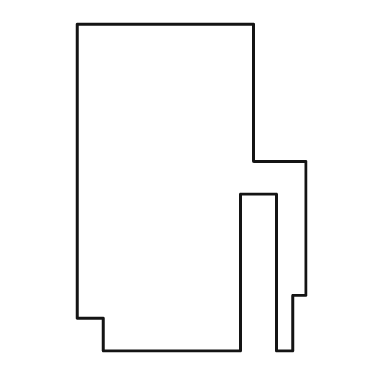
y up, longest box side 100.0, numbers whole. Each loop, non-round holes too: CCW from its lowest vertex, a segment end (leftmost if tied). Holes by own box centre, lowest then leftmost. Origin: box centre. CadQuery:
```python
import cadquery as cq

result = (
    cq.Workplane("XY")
    .moveTo(-27.0, -50.0)
    .lineTo(15.0, -50.0)
    .lineTo(15.0, -2.0)
    .lineTo(26.0, -2.0)
    .lineTo(26.0, -50.0)
    .lineTo(31.0, -50.0)
    .lineTo(31.0, -33.0)
    .lineTo(35.0, -33.0)
    .lineTo(35.0, 8.0)
    .lineTo(19.0, 8.0)
    .lineTo(19.0, 50.0)
    .lineTo(-35.0, 50.0)
    .lineTo(-35.0, -40.0)
    .lineTo(-27.0, -40.0)
    .close()
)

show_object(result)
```